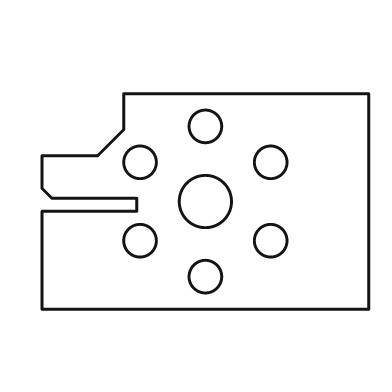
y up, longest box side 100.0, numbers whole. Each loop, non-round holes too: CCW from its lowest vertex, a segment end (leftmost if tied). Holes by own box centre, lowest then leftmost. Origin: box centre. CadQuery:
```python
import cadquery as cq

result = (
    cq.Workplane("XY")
    .moveTo(-50.0, -33.0)
    .lineTo(50.0, -33.0)
    .lineTo(50.0, 33.0)
    .lineTo(-25.0, 33.0)
    .lineTo(-25.0, 22.0)
    .lineTo(-33.0, 14.0)
    .lineTo(-50.0, 14.0)
    .lineTo(-50.0, 4.0)
    .lineTo(-47.0, 1.0)
    .lineTo(-21.0, 1.0)
    .lineTo(-21.0, -3.0)
    .lineTo(-50.0, -3.0)
    .close()
    .moveTo(0.0, -23.0)
    .circle(5.0)
    .moveTo(-20.0, -12.0)
    .circle(5.0)
    .moveTo(20.0, -12.0)
    .circle(5.0)
    .moveTo(0.0, 0.0)
    .circle(8.0)
    .moveTo(-20.0, 12.0)
    .circle(5.0)
    .moveTo(20.0, 12.0)
    .circle(5.0)
    .moveTo(0.0, 23.0)
    .circle(5.0)
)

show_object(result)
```